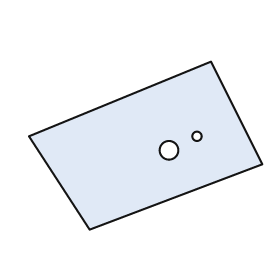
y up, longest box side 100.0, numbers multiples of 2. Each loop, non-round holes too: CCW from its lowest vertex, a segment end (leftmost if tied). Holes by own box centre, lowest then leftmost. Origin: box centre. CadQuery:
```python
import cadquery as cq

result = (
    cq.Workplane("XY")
    .moveTo(-24.0, -36.0)
    .lineTo(50.0, -8.0)
    .lineTo(28.0, 36.0)
    .lineTo(-50.0, 4.0)
    .close()
    .moveTo(10.0, -2.0)
    .circle(4.0)
    .moveTo(22.0, 4.0)
    .circle(2.0)
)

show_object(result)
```